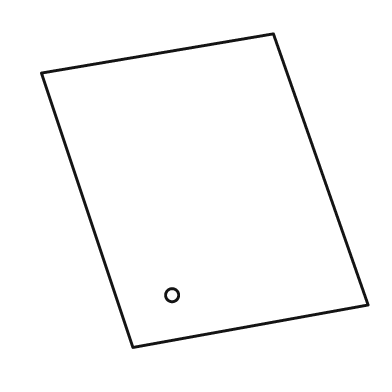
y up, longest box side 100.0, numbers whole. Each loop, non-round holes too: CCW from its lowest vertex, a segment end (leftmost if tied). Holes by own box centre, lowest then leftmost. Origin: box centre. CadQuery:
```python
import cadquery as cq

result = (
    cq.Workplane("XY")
    .moveTo(-22.0, -48.0)
    .lineTo(50.0, -35.0)
    .lineTo(21.0, 48.0)
    .lineTo(-50.0, 36.0)
    .close()
    .moveTo(-10.0, -32.0)
    .circle(2.0)
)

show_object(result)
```